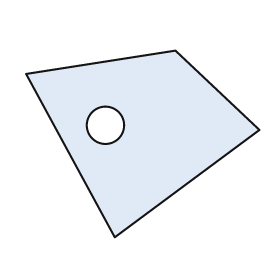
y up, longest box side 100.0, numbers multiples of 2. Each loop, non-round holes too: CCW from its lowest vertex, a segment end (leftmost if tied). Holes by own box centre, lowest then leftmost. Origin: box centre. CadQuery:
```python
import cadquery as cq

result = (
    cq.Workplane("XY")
    .moveTo(-12.0, -40.0)
    .lineTo(50.0, 6.0)
    .lineTo(14.0, 40.0)
    .lineTo(-50.0, 30.0)
    .close()
    .moveTo(-16.0, 8.0)
    .circle(8.0)
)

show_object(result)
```